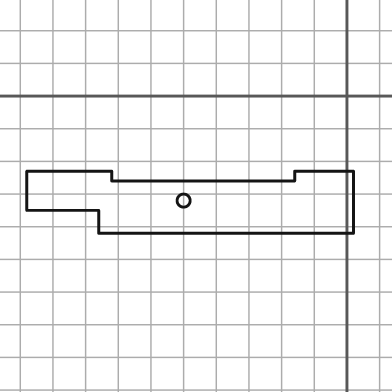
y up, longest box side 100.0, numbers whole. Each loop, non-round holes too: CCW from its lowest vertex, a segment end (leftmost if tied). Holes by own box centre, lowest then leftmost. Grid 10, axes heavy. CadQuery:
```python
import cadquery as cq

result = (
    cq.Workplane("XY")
    .moveTo(-76.0, -42.0)
    .lineTo(2.0, -42.0)
    .lineTo(2.0, -23.0)
    .lineTo(-16.0, -23.0)
    .lineTo(-16.0, -26.0)
    .lineTo(-72.0, -26.0)
    .lineTo(-72.0, -23.0)
    .lineTo(-98.0, -23.0)
    .lineTo(-98.0, -35.0)
    .lineTo(-76.0, -35.0)
    .close()
    .moveTo(-50.0, -32.0)
    .circle(2.0)
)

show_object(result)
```